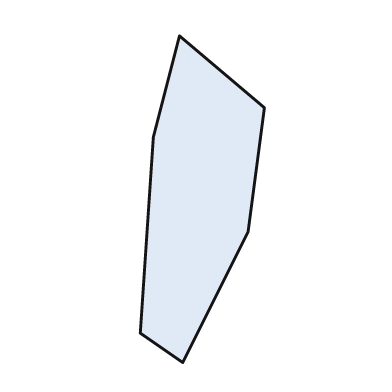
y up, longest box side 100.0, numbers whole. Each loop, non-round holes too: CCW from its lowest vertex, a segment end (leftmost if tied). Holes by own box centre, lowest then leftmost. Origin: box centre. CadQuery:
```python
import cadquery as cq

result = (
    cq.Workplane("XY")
    .moveTo(-6.0, -50.0)
    .lineTo(14.0, -10.0)
    .lineTo(19.0, 28.0)
    .lineTo(-7.0, 50.0)
    .lineTo(-15.0, 19.0)
    .lineTo(-19.0, -41.0)
    .close()
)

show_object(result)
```